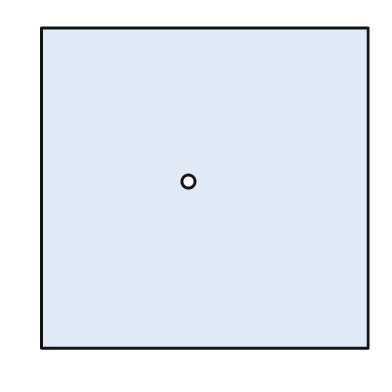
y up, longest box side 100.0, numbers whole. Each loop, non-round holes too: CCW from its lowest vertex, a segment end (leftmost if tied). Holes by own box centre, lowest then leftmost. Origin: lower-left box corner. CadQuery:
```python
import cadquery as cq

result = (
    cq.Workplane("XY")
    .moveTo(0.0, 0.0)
    .lineTo(100.0, 0.0)
    .lineTo(100.0, 98.0)
    .lineTo(0.0, 98.0)
    .close()
    .moveTo(45.0, 51.0)
    .circle(2.0)
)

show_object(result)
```